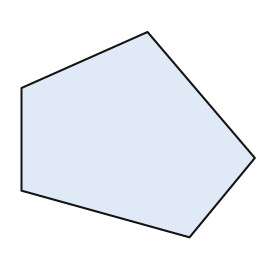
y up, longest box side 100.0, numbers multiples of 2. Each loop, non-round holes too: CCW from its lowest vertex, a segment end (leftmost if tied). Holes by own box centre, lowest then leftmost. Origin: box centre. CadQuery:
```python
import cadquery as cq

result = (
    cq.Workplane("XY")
    .moveTo(22.0, -44.0)
    .lineTo(50.0, -10.0)
    .lineTo(4.0, 44.0)
    .lineTo(-50.0, 20.0)
    .lineTo(-50.0, -24.0)
    .close()
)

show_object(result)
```